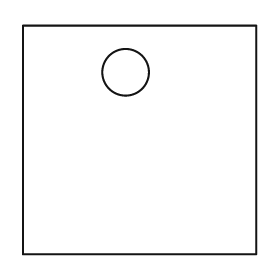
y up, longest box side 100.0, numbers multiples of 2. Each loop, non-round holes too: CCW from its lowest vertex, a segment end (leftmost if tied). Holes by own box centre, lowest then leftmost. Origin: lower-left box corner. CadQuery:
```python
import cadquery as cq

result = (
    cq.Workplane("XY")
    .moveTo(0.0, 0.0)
    .lineTo(100.0, 0.0)
    .lineTo(100.0, 98.0)
    .lineTo(0.0, 98.0)
    .close()
    .moveTo(44.0, 78.0)
    .circle(10.0)
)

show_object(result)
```